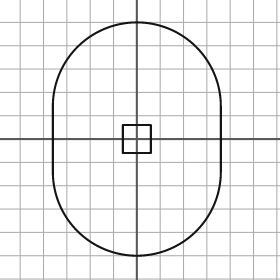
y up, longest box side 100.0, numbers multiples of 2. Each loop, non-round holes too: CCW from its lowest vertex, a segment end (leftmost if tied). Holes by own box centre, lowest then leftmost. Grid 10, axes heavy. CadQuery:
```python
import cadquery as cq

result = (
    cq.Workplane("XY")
    .moveTo(-36.0, -14.0)
    .threePointArc((0.0, -50.0), (36.0, -14.0))
    .lineTo(36.0, 14.0)
    .threePointArc((0.0, 50.0), (-36.0, 14.0))
    .close()
    .moveTo(-6.0, -6.0)
    .lineTo(6.0, -6.0)
    .lineTo(6.0, 6.0)
    .lineTo(-6.0, 6.0)
    .close()
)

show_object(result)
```